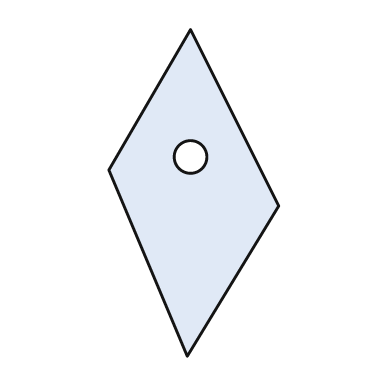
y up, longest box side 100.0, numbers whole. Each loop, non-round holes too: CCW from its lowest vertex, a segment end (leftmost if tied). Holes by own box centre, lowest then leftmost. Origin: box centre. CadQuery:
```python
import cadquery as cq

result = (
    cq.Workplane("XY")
    .moveTo(-2.0, -50.0)
    .lineTo(26.0, -4.0)
    .lineTo(-1.0, 50.0)
    .lineTo(-26.0, 7.0)
    .close()
    .moveTo(-1.0, 11.0)
    .circle(5.0)
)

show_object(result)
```